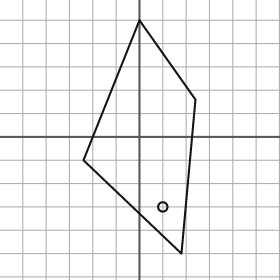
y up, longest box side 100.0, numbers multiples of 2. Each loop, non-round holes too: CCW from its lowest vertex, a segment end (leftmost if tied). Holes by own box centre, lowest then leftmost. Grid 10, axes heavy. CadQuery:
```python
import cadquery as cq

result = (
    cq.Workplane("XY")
    .moveTo(18.0, -50.0)
    .lineTo(24.0, 16.0)
    .lineTo(0.0, 50.0)
    .lineTo(-24.0, -10.0)
    .close()
    .moveTo(10.0, -30.0)
    .circle(2.0)
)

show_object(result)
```